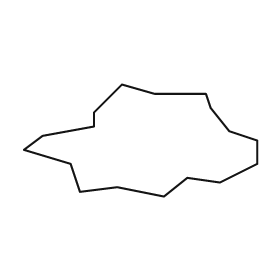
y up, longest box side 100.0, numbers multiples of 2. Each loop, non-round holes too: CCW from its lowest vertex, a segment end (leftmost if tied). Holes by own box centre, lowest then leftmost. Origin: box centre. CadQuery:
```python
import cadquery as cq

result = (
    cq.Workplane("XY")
    .moveTo(10.0, -24.0)
    .lineTo(20.0, -16.0)
    .lineTo(34.0, -18.0)
    .lineTo(50.0, -10.0)
    .lineTo(50.0, 0.0)
    .lineTo(38.0, 4.0)
    .lineTo(30.0, 14.0)
    .lineTo(28.0, 20.0)
    .lineTo(6.0, 20.0)
    .lineTo(-8.0, 24.0)
    .lineTo(-20.0, 12.0)
    .lineTo(-20.0, 6.0)
    .lineTo(-42.0, 2.0)
    .lineTo(-50.0, -4.0)
    .lineTo(-30.0, -10.0)
    .lineTo(-26.0, -22.0)
    .lineTo(-10.0, -20.0)
    .close()
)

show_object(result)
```